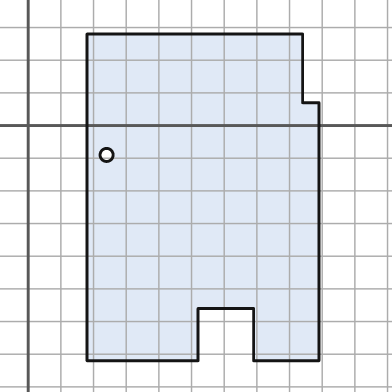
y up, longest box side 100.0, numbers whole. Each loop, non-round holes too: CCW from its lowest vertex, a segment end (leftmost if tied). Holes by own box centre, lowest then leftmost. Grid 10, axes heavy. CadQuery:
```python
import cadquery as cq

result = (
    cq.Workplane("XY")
    .moveTo(18.0, -72.0)
    .lineTo(52.0, -72.0)
    .lineTo(52.0, -56.0)
    .lineTo(69.0, -56.0)
    .lineTo(69.0, -72.0)
    .lineTo(89.0, -72.0)
    .lineTo(89.0, 7.0)
    .lineTo(84.0, 7.0)
    .lineTo(84.0, 28.0)
    .lineTo(18.0, 28.0)
    .close()
    .moveTo(24.0, -9.0)
    .circle(2.0)
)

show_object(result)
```